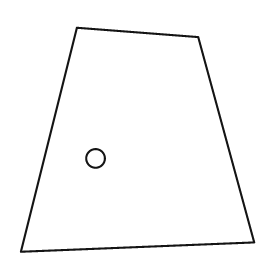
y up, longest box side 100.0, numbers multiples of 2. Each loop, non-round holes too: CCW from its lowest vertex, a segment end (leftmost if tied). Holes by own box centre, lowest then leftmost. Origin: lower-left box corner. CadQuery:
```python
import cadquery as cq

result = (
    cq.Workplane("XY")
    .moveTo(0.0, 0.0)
    .lineTo(100.0, 4.0)
    .lineTo(76.0, 92.0)
    .lineTo(24.0, 96.0)
    .close()
    .moveTo(32.0, 40.0)
    .circle(4.0)
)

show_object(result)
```